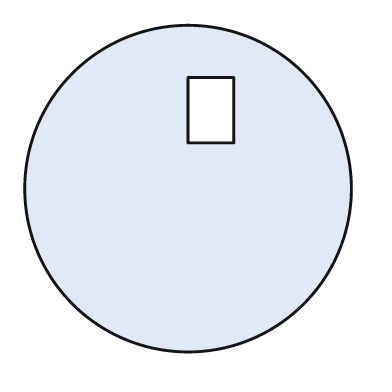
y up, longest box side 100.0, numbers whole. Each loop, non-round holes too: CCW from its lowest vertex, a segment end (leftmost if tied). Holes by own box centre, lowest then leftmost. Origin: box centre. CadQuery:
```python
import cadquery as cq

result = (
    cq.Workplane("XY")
    .moveTo(0.0, 0.0)
    .circle(50.0)
    .moveTo(0.0, 14.0)
    .lineTo(14.0, 14.0)
    .lineTo(14.0, 34.0)
    .lineTo(0.0, 34.0)
    .close()
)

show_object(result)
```